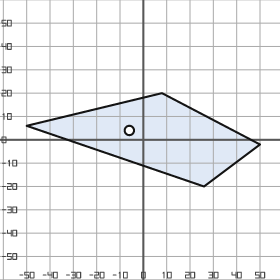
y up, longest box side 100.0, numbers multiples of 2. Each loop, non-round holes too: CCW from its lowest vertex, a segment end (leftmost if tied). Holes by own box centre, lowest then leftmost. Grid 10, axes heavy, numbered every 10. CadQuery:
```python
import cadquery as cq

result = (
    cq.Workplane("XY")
    .moveTo(26.0, -20.0)
    .lineTo(50.0, -2.0)
    .lineTo(8.0, 20.0)
    .lineTo(-50.0, 6.0)
    .close()
    .moveTo(-6.0, 4.0)
    .circle(2.0)
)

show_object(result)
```